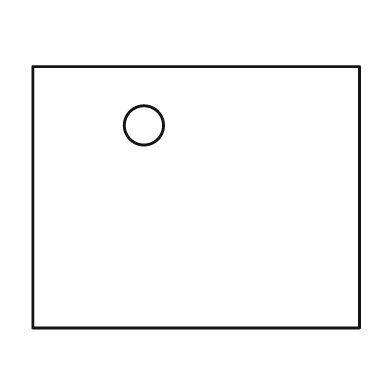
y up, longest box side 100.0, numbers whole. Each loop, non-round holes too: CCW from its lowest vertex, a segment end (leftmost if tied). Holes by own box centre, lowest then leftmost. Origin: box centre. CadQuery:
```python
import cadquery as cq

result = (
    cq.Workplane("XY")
    .moveTo(-50.0, -40.0)
    .lineTo(50.0, -40.0)
    .lineTo(50.0, 40.0)
    .lineTo(-50.0, 40.0)
    .close()
    .moveTo(-16.0, 22.0)
    .circle(6.0)
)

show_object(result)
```